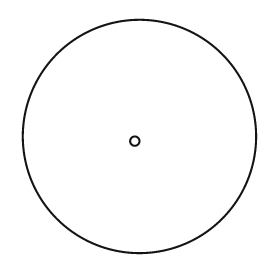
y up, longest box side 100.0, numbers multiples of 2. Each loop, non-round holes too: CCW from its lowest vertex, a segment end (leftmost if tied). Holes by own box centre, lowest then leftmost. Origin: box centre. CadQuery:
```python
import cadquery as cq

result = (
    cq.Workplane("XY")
    .moveTo(0.0, 0.0)
    .circle(50.0)
    .moveTo(-2.0, -2.0)
    .circle(2.0)
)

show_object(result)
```